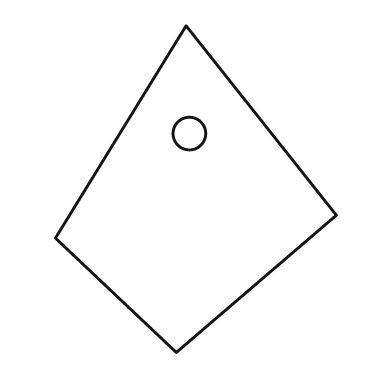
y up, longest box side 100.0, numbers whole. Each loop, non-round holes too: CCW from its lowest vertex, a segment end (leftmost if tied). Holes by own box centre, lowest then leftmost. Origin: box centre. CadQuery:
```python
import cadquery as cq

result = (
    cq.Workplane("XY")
    .moveTo(-6.0, -50.0)
    .lineTo(43.0, -8.0)
    .lineTo(-3.0, 50.0)
    .lineTo(-43.0, -15.0)
    .close()
    .moveTo(-2.0, 17.0)
    .circle(5.0)
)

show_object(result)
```